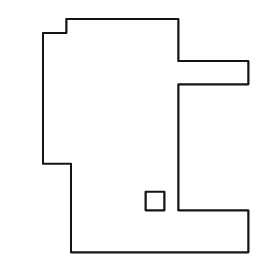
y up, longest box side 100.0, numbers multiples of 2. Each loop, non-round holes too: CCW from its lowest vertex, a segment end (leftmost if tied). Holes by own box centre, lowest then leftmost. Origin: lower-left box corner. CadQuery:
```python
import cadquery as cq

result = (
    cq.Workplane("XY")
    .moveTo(12.0, 0.0)
    .lineTo(88.0, 0.0)
    .lineTo(88.0, 18.0)
    .lineTo(58.0, 18.0)
    .lineTo(58.0, 72.0)
    .lineTo(88.0, 72.0)
    .lineTo(88.0, 82.0)
    .lineTo(58.0, 82.0)
    .lineTo(58.0, 100.0)
    .lineTo(10.0, 100.0)
    .lineTo(10.0, 94.0)
    .lineTo(0.0, 94.0)
    .lineTo(0.0, 38.0)
    .lineTo(12.0, 38.0)
    .close()
    .moveTo(44.0, 18.0)
    .lineTo(52.0, 18.0)
    .lineTo(52.0, 26.0)
    .lineTo(44.0, 26.0)
    .close()
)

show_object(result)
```